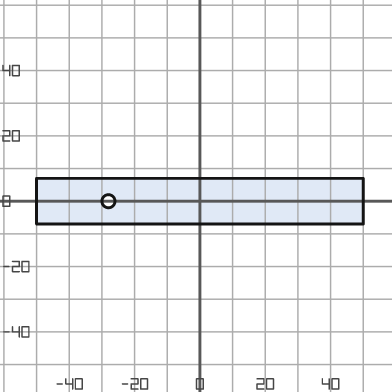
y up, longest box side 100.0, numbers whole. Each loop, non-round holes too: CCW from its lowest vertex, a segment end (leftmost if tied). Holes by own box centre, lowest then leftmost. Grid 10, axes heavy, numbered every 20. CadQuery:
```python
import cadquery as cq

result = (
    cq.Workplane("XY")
    .moveTo(-50.0, -7.0)
    .lineTo(50.0, -7.0)
    .lineTo(50.0, 7.0)
    .lineTo(-50.0, 7.0)
    .close()
    .moveTo(-28.0, 0.0)
    .circle(2.0)
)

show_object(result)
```